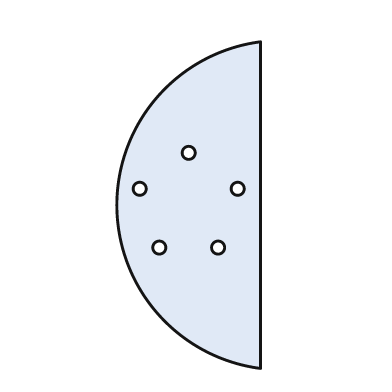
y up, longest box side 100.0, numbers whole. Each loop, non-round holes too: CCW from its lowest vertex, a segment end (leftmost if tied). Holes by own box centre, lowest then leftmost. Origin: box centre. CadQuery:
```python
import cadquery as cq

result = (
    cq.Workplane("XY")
    .moveTo(22.0, -50.0)
    .lineTo(22.0, 50.0)
    .threePointArc((-22.0, 0.0), (22.0, -50.0))
    .close()
    .moveTo(-9.0, -13.0)
    .circle(2.0)
    .moveTo(9.0, -13.0)
    .circle(2.0)
    .moveTo(-15.0, 5.0)
    .circle(2.0)
    .moveTo(15.0, 5.0)
    .circle(2.0)
    .moveTo(0.0, 16.0)
    .circle(2.0)
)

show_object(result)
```